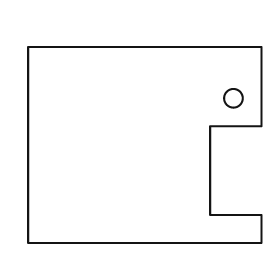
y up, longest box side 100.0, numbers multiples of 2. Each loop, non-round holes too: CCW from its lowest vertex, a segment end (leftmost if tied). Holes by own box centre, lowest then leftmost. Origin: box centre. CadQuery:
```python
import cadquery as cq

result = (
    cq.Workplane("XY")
    .moveTo(-50.0, -42.0)
    .lineTo(50.0, -42.0)
    .lineTo(50.0, -30.0)
    .lineTo(28.0, -30.0)
    .lineTo(28.0, 8.0)
    .lineTo(50.0, 8.0)
    .lineTo(50.0, 42.0)
    .lineTo(-50.0, 42.0)
    .close()
    .moveTo(38.0, 20.0)
    .circle(4.0)
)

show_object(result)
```